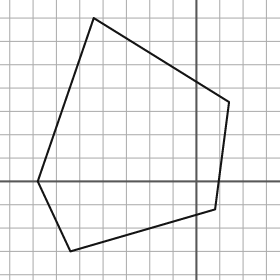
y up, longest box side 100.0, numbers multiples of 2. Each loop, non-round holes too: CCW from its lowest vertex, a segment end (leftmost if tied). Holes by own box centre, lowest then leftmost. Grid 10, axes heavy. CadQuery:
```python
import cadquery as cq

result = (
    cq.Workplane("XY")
    .moveTo(-54.0, -30.0)
    .lineTo(8.0, -12.0)
    .lineTo(14.0, 34.0)
    .lineTo(-44.0, 70.0)
    .lineTo(-68.0, 0.0)
    .close()
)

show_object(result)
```